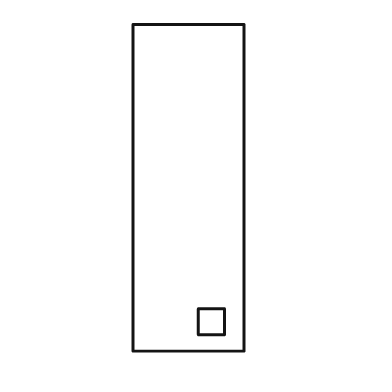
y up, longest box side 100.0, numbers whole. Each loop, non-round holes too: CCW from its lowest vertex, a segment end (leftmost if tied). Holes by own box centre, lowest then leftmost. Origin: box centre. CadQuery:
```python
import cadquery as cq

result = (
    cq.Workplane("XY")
    .moveTo(-17.0, -50.0)
    .lineTo(17.0, -50.0)
    .lineTo(17.0, 50.0)
    .lineTo(-17.0, 50.0)
    .close()
    .moveTo(3.0, -45.0)
    .lineTo(11.0, -45.0)
    .lineTo(11.0, -37.0)
    .lineTo(3.0, -37.0)
    .close()
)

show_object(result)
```